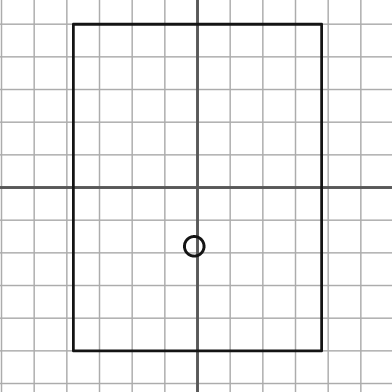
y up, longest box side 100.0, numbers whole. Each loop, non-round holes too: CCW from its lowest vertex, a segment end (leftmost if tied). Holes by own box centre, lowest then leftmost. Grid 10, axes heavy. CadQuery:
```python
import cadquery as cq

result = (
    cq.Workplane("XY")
    .moveTo(-38.0, -50.0)
    .lineTo(38.0, -50.0)
    .lineTo(38.0, 50.0)
    .lineTo(-38.0, 50.0)
    .close()
    .moveTo(-1.0, -18.0)
    .circle(3.0)
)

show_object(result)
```